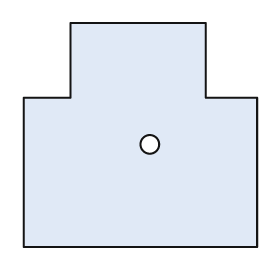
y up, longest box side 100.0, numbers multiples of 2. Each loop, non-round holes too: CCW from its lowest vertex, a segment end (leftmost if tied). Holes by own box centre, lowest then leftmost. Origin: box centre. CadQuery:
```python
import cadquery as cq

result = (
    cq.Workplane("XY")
    .moveTo(-50.0, -48.0)
    .lineTo(50.0, -48.0)
    .lineTo(50.0, 16.0)
    .lineTo(28.0, 16.0)
    .lineTo(28.0, 48.0)
    .lineTo(-30.0, 48.0)
    .lineTo(-30.0, 16.0)
    .lineTo(-50.0, 16.0)
    .close()
    .moveTo(4.0, -4.0)
    .circle(4.0)
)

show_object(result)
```